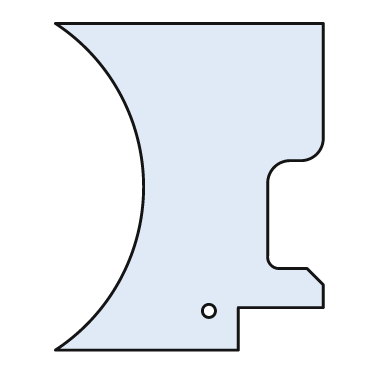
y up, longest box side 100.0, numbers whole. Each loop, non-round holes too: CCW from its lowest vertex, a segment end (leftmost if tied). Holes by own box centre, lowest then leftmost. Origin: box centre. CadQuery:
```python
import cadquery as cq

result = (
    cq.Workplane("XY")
    .moveTo(-41.0, -50.0)
    .lineTo(15.0, -50.0)
    .lineTo(15.0, -37.0)
    .lineTo(41.0, -37.0)
    .lineTo(41.0, -30.0)
    .lineTo(36.0, -25.0)
    .lineTo(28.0, -25.0)
    .threePointArc((25.0, -24.0), (24.0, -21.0))
    .lineTo(24.0, 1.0)
    .threePointArc((26.0, 6.0), (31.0, 8.0))
    .lineTo(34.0, 8.0)
    .threePointArc((39.0, 10.0), (41.0, 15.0))
    .lineTo(41.0, 50.0)
    .lineTo(-41.0, 50.0)
    .threePointArc((-14.0, 0.0), (-41.0, -50.0))
    .close()
    .moveTo(6.0, -38.0)
    .circle(2.0)
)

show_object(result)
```